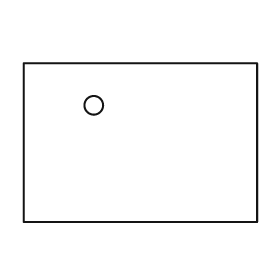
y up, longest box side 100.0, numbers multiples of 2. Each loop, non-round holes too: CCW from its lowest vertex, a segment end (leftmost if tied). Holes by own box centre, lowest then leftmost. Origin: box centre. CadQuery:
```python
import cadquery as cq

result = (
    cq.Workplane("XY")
    .moveTo(-50.0, -34.0)
    .lineTo(50.0, -34.0)
    .lineTo(50.0, 34.0)
    .lineTo(-50.0, 34.0)
    .close()
    .moveTo(-20.0, 16.0)
    .circle(4.0)
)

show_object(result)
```